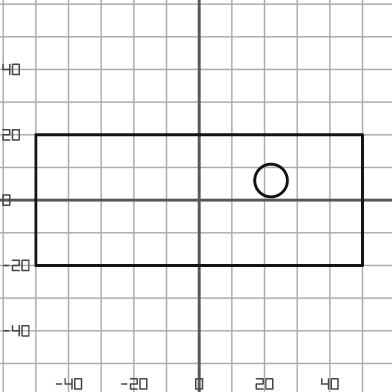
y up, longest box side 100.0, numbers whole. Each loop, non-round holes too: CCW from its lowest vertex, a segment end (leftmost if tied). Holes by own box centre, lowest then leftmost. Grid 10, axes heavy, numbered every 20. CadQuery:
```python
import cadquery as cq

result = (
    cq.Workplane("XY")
    .moveTo(-50.0, -20.0)
    .lineTo(50.0, -20.0)
    .lineTo(50.0, 20.0)
    .lineTo(-50.0, 20.0)
    .close()
    .moveTo(22.0, 6.0)
    .circle(5.0)
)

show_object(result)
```